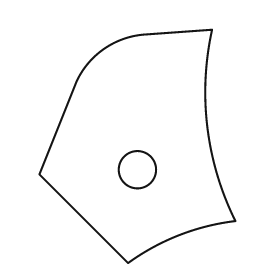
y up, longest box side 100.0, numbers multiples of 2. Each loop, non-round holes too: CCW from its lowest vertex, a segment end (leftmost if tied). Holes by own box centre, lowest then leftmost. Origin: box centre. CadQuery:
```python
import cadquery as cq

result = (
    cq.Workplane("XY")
    .moveTo(-4.0, -50.0)
    .threePointArc((18.0, -38.0), (42.0, -32.0))
    .threePointArc((30.0, 8.0), (32.0, 50.0))
    .lineTo(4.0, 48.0)
    .threePointArc((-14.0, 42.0), (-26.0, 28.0))
    .lineTo(-42.0, -12.0)
    .close()
    .moveTo(0.0, -10.0)
    .circle(8.0)
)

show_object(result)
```